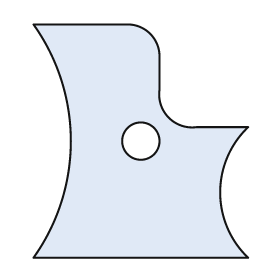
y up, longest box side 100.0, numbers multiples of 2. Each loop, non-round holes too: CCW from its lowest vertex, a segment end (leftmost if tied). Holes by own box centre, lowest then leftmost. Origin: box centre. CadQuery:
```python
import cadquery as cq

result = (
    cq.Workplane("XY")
    .moveTo(-46.0, -50.0)
    .lineTo(46.0, -50.0)
    .threePointArc((34.0, -22.0), (46.0, 6.0))
    .lineTo(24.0, 6.0)
    .threePointArc((12.0, 10.0), (8.0, 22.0))
    .lineTo(8.0, 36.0)
    .threePointArc((4.0, 46.0), (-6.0, 50.0))
    .lineTo(-46.0, 50.0)
    .threePointArc((-30.0, 0.0), (-46.0, -50.0))
    .close()
    .moveTo(0.0, 0.0)
    .circle(8.0)
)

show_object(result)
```